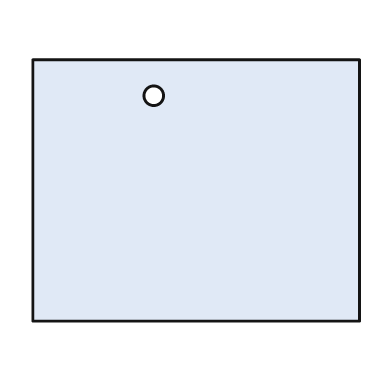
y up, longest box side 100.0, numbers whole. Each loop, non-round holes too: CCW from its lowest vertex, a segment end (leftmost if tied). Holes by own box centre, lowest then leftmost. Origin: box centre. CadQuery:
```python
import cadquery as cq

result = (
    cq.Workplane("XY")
    .moveTo(-50.0, -40.0)
    .lineTo(50.0, -40.0)
    .lineTo(50.0, 40.0)
    .lineTo(-50.0, 40.0)
    .close()
    .moveTo(-13.0, 29.0)
    .circle(3.0)
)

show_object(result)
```